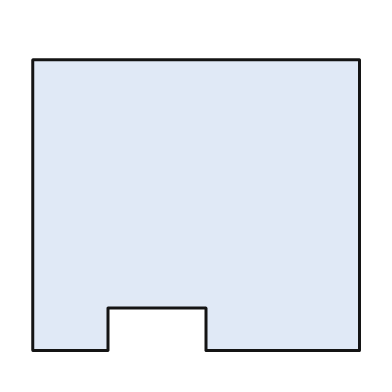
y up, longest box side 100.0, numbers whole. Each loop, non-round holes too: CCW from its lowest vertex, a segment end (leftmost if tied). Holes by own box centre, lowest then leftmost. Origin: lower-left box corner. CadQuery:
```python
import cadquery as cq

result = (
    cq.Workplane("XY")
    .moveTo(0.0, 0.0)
    .lineTo(23.0, 0.0)
    .lineTo(23.0, 13.0)
    .lineTo(53.0, 13.0)
    .lineTo(53.0, 0.0)
    .lineTo(100.0, 0.0)
    .lineTo(100.0, 89.0)
    .lineTo(0.0, 89.0)
    .close()
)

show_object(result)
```